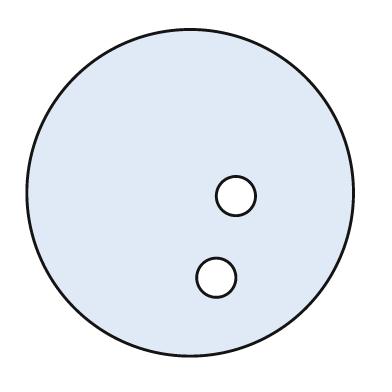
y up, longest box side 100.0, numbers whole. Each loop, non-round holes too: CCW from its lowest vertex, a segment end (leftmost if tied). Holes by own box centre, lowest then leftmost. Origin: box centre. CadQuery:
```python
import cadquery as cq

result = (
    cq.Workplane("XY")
    .moveTo(0.0, 0.0)
    .circle(50.0)
    .moveTo(8.0, -26.0)
    .circle(6.0)
    .moveTo(14.0, -1.0)
    .circle(6.0)
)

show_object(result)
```